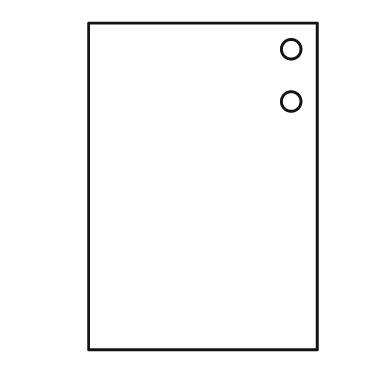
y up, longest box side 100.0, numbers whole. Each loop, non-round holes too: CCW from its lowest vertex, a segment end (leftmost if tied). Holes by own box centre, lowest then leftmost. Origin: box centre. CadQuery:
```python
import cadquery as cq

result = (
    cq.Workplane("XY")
    .moveTo(-35.0, -50.0)
    .lineTo(35.0, -50.0)
    .lineTo(35.0, 50.0)
    .lineTo(-35.0, 50.0)
    .close()
    .moveTo(27.0, 26.0)
    .circle(3.0)
    .moveTo(27.0, 42.0)
    .circle(3.0)
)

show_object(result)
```